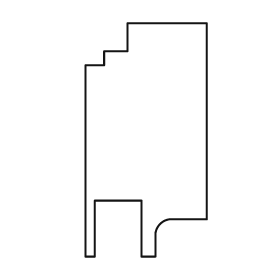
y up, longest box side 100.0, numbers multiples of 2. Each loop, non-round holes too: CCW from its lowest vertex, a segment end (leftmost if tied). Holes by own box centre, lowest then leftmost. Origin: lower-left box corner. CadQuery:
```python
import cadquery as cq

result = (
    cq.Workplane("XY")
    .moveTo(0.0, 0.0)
    .lineTo(4.0, 0.0)
    .lineTo(4.0, 24.0)
    .lineTo(24.0, 24.0)
    .lineTo(24.0, 0.0)
    .lineTo(30.0, 0.0)
    .lineTo(30.0, 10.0)
    .threePointArc((32.0, 14.0), (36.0, 16.0))
    .lineTo(52.0, 16.0)
    .lineTo(52.0, 100.0)
    .lineTo(18.0, 100.0)
    .lineTo(18.0, 88.0)
    .lineTo(8.0, 88.0)
    .lineTo(8.0, 82.0)
    .lineTo(0.0, 82.0)
    .close()
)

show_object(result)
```